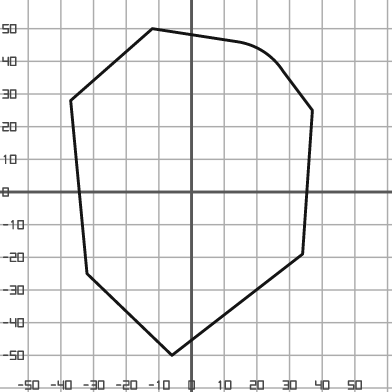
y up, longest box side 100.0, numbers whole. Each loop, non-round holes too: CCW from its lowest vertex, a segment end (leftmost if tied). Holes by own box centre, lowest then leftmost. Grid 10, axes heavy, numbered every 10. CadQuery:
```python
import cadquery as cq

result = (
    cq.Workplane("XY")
    .moveTo(-6.0, -50.0)
    .lineTo(34.0, -19.0)
    .lineTo(37.0, 25.0)
    .lineTo(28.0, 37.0)
    .threePointArc((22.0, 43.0), (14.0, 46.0))
    .lineTo(-12.0, 50.0)
    .lineTo(-37.0, 28.0)
    .lineTo(-32.0, -25.0)
    .close()
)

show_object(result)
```